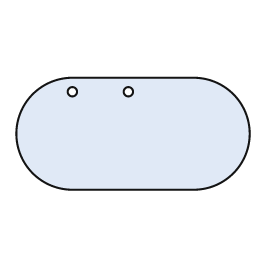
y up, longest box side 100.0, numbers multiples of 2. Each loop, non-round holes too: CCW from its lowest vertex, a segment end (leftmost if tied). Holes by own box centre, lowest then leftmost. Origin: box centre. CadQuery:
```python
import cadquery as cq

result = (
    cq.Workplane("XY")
    .moveTo(-26.0, -24.0)
    .lineTo(26.0, -24.0)
    .threePointArc((50.0, 0.0), (26.0, 24.0))
    .lineTo(-26.0, 24.0)
    .threePointArc((-50.0, 0.0), (-26.0, -24.0))
    .close()
    .moveTo(-26.0, 18.0)
    .circle(2.0)
    .moveTo(-2.0, 18.0)
    .circle(2.0)
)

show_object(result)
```